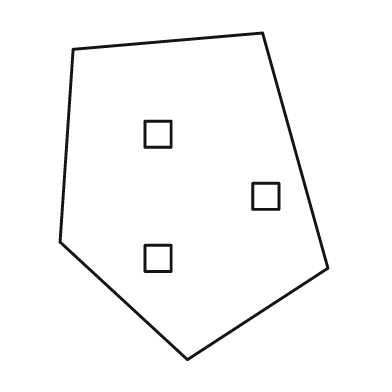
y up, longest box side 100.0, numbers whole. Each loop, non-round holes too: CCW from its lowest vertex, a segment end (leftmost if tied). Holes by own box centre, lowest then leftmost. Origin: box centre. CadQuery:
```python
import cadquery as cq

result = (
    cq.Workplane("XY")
    .moveTo(-2.0, -50.0)
    .lineTo(41.0, -22.0)
    .lineTo(21.0, 50.0)
    .lineTo(-37.0, 45.0)
    .lineTo(-41.0, -14.0)
    .close()
    .moveTo(-15.0, -23.0)
    .lineTo(-7.0, -23.0)
    .lineTo(-7.0, -15.0)
    .lineTo(-15.0, -15.0)
    .close()
    .moveTo(18.0, -4.0)
    .lineTo(26.0, -4.0)
    .lineTo(26.0, 4.0)
    .lineTo(18.0, 4.0)
    .close()
    .moveTo(-15.0, 15.0)
    .lineTo(-7.0, 15.0)
    .lineTo(-7.0, 23.0)
    .lineTo(-15.0, 23.0)
    .close()
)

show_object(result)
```